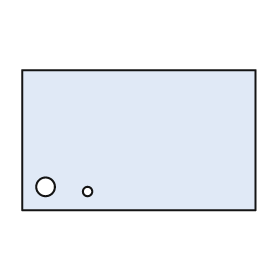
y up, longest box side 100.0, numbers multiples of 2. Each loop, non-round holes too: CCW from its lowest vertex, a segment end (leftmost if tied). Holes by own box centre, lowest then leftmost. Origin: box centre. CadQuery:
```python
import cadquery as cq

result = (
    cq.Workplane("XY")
    .moveTo(-50.0, -30.0)
    .lineTo(50.0, -30.0)
    .lineTo(50.0, 30.0)
    .lineTo(-50.0, 30.0)
    .close()
    .moveTo(-22.0, -22.0)
    .circle(2.0)
    .moveTo(-40.0, -20.0)
    .circle(4.0)
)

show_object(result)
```